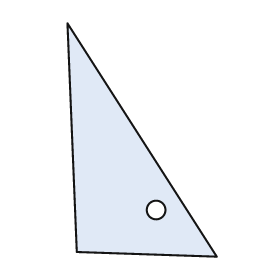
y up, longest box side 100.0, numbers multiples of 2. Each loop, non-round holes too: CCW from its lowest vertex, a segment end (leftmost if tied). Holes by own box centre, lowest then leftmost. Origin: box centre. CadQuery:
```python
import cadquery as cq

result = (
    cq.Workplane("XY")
    .moveTo(32.0, -50.0)
    .lineTo(-32.0, 50.0)
    .lineTo(-28.0, -48.0)
    .close()
    .moveTo(6.0, -30.0)
    .circle(4.0)
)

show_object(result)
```